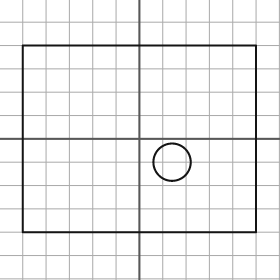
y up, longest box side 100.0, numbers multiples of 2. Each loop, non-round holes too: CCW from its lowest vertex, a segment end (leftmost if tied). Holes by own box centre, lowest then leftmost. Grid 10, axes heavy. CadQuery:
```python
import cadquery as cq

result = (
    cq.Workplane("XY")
    .moveTo(-50.0, -40.0)
    .lineTo(50.0, -40.0)
    .lineTo(50.0, 40.0)
    .lineTo(-50.0, 40.0)
    .close()
    .moveTo(14.0, -10.0)
    .circle(8.0)
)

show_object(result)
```